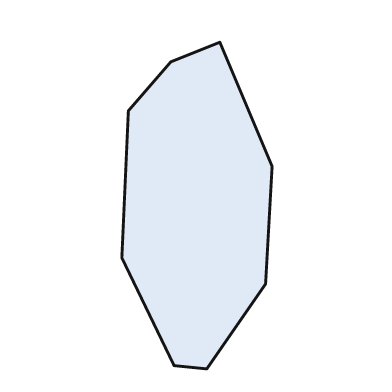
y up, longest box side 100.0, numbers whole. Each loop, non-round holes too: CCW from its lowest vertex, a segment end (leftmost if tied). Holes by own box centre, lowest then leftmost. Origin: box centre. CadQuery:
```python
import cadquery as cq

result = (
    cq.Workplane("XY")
    .moveTo(3.0, -50.0)
    .lineTo(21.0, -24.0)
    .lineTo(23.0, 12.0)
    .lineTo(7.0, 50.0)
    .lineTo(-8.0, 44.0)
    .lineTo(-21.0, 29.0)
    .lineTo(-23.0, -16.0)
    .lineTo(-7.0, -49.0)
    .close()
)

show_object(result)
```